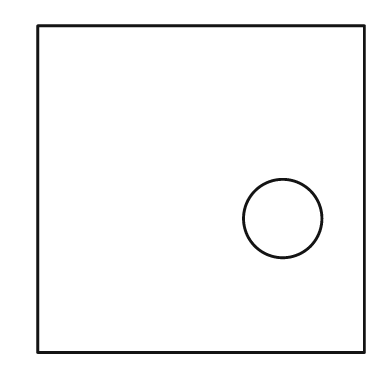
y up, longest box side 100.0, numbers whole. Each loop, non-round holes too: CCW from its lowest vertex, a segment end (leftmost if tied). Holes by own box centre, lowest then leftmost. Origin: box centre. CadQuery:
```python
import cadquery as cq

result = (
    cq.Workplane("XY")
    .moveTo(-50.0, -50.0)
    .lineTo(50.0, -50.0)
    .lineTo(50.0, 50.0)
    .lineTo(-50.0, 50.0)
    .close()
    .moveTo(25.0, -9.0)
    .circle(12.0)
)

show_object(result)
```